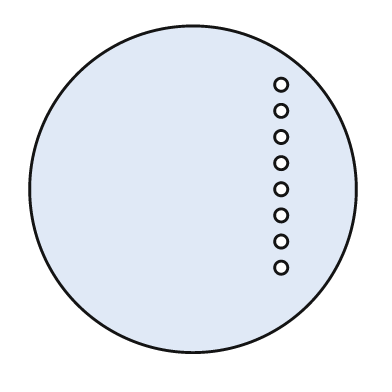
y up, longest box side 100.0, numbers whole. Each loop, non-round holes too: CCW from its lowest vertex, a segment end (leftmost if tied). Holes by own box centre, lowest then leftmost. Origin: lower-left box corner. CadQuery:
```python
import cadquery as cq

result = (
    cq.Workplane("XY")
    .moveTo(50.0, 50.0)
    .circle(50.0)
    .moveTo(77.0, 26.0)
    .circle(2.0)
    .moveTo(77.0, 34.0)
    .circle(2.0)
    .moveTo(77.0, 42.0)
    .circle(2.0)
    .moveTo(77.0, 50.0)
    .circle(2.0)
    .moveTo(77.0, 58.0)
    .circle(2.0)
    .moveTo(77.0, 66.0)
    .circle(2.0)
    .moveTo(77.0, 74.0)
    .circle(2.0)
    .moveTo(77.0, 82.0)
    .circle(2.0)
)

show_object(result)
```